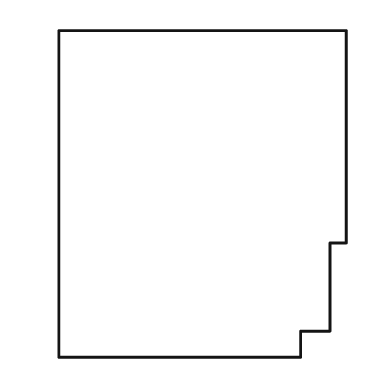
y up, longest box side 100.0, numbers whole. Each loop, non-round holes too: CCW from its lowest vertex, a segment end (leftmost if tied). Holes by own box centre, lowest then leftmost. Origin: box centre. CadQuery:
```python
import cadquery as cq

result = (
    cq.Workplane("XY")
    .moveTo(-44.0, -50.0)
    .lineTo(30.0, -50.0)
    .lineTo(30.0, -42.0)
    .lineTo(39.0, -42.0)
    .lineTo(39.0, -15.0)
    .lineTo(44.0, -15.0)
    .lineTo(44.0, 50.0)
    .lineTo(-44.0, 50.0)
    .close()
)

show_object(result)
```